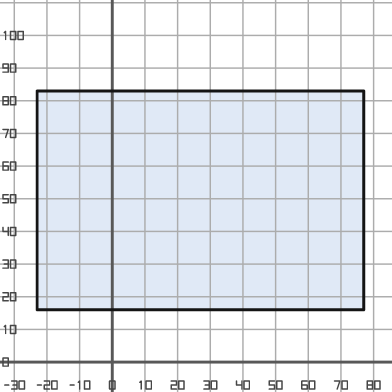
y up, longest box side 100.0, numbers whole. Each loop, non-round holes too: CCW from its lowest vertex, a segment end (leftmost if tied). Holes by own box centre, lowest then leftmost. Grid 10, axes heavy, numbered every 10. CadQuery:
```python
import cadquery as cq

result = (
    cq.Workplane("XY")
    .moveTo(-23.0, 16.0)
    .lineTo(77.0, 16.0)
    .lineTo(77.0, 83.0)
    .lineTo(-23.0, 83.0)
    .close()
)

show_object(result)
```